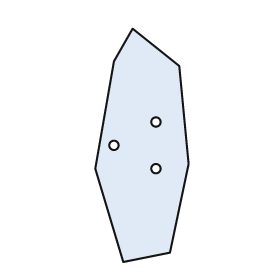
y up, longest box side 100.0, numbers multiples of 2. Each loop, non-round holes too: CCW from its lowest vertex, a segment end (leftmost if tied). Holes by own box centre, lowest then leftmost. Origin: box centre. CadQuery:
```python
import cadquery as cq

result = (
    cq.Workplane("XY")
    .moveTo(-8.0, -50.0)
    .lineTo(12.0, -46.0)
    .lineTo(20.0, -8.0)
    .lineTo(16.0, 34.0)
    .lineTo(-4.0, 50.0)
    .lineTo(-12.0, 36.0)
    .lineTo(-20.0, -10.0)
    .close()
    .moveTo(6.0, -10.0)
    .circle(2.0)
    .moveTo(-12.0, 0.0)
    .circle(2.0)
    .moveTo(6.0, 10.0)
    .circle(2.0)
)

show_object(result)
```